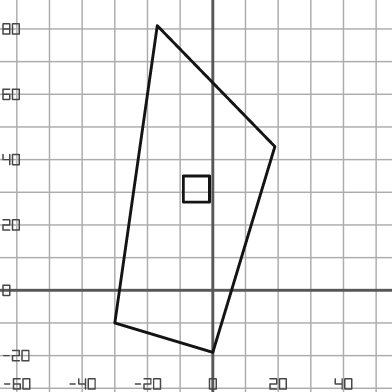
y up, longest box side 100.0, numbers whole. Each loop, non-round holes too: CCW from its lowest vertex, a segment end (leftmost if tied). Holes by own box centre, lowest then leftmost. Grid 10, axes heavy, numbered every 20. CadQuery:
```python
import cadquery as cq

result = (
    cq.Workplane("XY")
    .moveTo(0.0, -19.0)
    .lineTo(19.0, 44.0)
    .lineTo(-17.0, 81.0)
    .lineTo(-30.0, -10.0)
    .close()
    .moveTo(-9.0, 27.0)
    .lineTo(-1.0, 27.0)
    .lineTo(-1.0, 35.0)
    .lineTo(-9.0, 35.0)
    .close()
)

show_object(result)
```